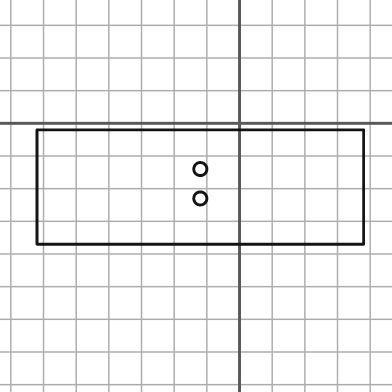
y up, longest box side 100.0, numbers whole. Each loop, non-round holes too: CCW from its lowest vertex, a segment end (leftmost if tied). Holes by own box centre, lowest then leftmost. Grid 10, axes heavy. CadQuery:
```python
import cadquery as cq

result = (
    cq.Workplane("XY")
    .moveTo(-62.0, -37.0)
    .lineTo(38.0, -37.0)
    .lineTo(38.0, -2.0)
    .lineTo(-62.0, -2.0)
    .close()
    .moveTo(-12.0, -23.0)
    .circle(2.0)
    .moveTo(-12.0, -14.0)
    .circle(2.0)
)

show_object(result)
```